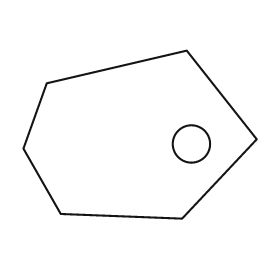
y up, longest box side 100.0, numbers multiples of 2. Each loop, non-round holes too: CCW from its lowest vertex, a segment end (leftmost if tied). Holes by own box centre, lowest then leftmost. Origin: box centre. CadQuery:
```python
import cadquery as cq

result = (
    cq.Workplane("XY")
    .moveTo(18.0, -36.0)
    .lineTo(50.0, -2.0)
    .lineTo(20.0, 36.0)
    .lineTo(-40.0, 22.0)
    .lineTo(-50.0, -6.0)
    .lineTo(-34.0, -34.0)
    .close()
    .moveTo(22.0, -4.0)
    .circle(8.0)
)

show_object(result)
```